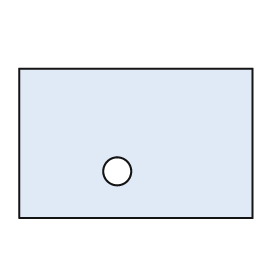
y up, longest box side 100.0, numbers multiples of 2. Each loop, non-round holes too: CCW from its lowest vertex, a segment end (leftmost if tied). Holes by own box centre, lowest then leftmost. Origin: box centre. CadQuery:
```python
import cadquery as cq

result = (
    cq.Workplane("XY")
    .moveTo(-50.0, -32.0)
    .lineTo(50.0, -32.0)
    .lineTo(50.0, 32.0)
    .lineTo(-50.0, 32.0)
    .close()
    .moveTo(-8.0, -12.0)
    .circle(6.0)
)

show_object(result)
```